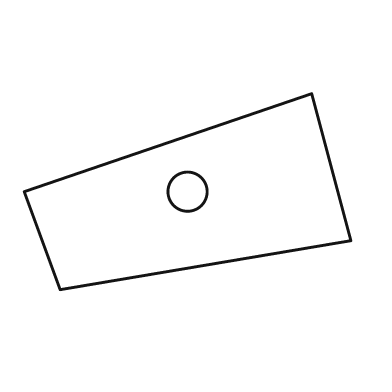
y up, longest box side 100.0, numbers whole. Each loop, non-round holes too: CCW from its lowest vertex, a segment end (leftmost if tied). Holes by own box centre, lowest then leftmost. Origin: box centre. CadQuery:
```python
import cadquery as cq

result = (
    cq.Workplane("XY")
    .moveTo(-39.0, -30.0)
    .lineTo(50.0, -15.0)
    .lineTo(38.0, 30.0)
    .lineTo(-50.0, 0.0)
    .close()
    .moveTo(0.0, 0.0)
    .circle(6.0)
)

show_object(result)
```